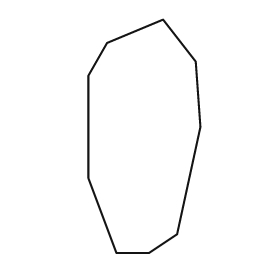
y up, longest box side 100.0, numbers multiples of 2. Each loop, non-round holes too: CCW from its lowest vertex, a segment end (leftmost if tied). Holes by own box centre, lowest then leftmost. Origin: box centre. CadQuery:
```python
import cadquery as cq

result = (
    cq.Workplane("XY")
    .moveTo(-12.0, -50.0)
    .lineTo(2.0, -50.0)
    .lineTo(14.0, -42.0)
    .lineTo(24.0, 4.0)
    .lineTo(22.0, 32.0)
    .lineTo(8.0, 50.0)
    .lineTo(-16.0, 40.0)
    .lineTo(-24.0, 26.0)
    .lineTo(-24.0, -18.0)
    .close()
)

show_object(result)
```